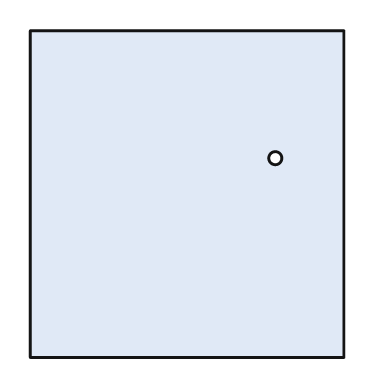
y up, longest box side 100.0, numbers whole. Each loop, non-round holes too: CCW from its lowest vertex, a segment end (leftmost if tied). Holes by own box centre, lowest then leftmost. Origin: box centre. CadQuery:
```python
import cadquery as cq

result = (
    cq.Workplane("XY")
    .moveTo(-48.0, -50.0)
    .lineTo(48.0, -50.0)
    .lineTo(48.0, 50.0)
    .lineTo(-48.0, 50.0)
    .close()
    .moveTo(27.0, 11.0)
    .circle(2.0)
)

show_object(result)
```